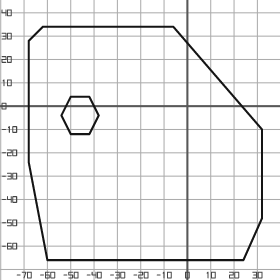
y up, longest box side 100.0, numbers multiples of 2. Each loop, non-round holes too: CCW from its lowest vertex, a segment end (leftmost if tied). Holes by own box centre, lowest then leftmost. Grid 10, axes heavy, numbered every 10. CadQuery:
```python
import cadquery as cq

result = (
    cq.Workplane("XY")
    .moveTo(-60.0, -66.0)
    .lineTo(24.0, -66.0)
    .lineTo(32.0, -48.0)
    .lineTo(32.0, -10.0)
    .lineTo(-6.0, 34.0)
    .lineTo(-62.0, 34.0)
    .lineTo(-68.0, 28.0)
    .lineTo(-68.0, -24.0)
    .close()
    .moveTo(-50.0, -12.0)
    .lineTo(-42.0, -12.0)
    .lineTo(-38.0, -4.0)
    .lineTo(-42.0, 4.0)
    .lineTo(-50.0, 4.0)
    .lineTo(-54.0, -4.0)
    .close()
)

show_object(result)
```